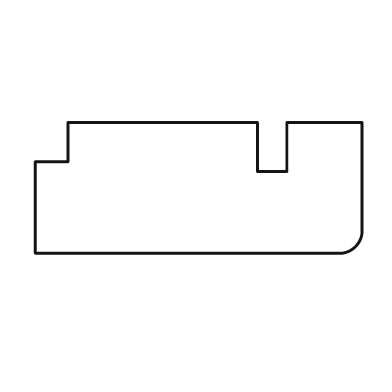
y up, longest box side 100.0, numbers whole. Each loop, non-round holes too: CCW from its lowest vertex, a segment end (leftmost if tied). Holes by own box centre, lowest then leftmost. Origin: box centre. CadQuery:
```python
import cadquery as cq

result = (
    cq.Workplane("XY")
    .moveTo(-50.0, -20.0)
    .lineTo(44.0, -20.0)
    .threePointArc((48.0, -18.0), (50.0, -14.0))
    .lineTo(50.0, 20.0)
    .lineTo(27.0, 20.0)
    .lineTo(27.0, 5.0)
    .lineTo(18.0, 5.0)
    .lineTo(18.0, 20.0)
    .lineTo(-40.0, 20.0)
    .lineTo(-40.0, 8.0)
    .lineTo(-50.0, 8.0)
    .close()
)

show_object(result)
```